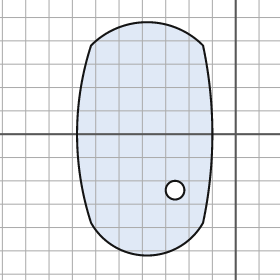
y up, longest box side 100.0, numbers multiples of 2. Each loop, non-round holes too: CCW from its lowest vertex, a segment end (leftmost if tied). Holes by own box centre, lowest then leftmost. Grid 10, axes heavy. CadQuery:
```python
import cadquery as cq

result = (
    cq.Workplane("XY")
    .moveTo(-62.0, -38.0)
    .threePointArc((-38.0, -52.0), (-14.0, -38.0))
    .threePointArc((-10.0, 0.0), (-14.0, 38.0))
    .threePointArc((-38.0, 48.0), (-62.0, 38.0))
    .threePointArc((-68.0, 0.0), (-62.0, -38.0))
    .close()
    .moveTo(-26.0, -24.0)
    .circle(4.0)
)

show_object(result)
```